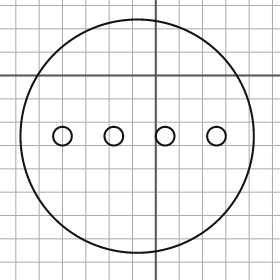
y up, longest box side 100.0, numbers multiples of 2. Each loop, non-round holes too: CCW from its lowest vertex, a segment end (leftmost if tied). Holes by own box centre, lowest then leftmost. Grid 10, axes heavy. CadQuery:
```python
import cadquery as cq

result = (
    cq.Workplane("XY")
    .moveTo(-8.0, -26.0)
    .circle(50.0)
    .moveTo(-40.0, -26.0)
    .circle(4.0)
    .moveTo(-18.0, -26.0)
    .circle(4.0)
    .moveTo(4.0, -26.0)
    .circle(4.0)
    .moveTo(26.0, -26.0)
    .circle(4.0)
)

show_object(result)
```